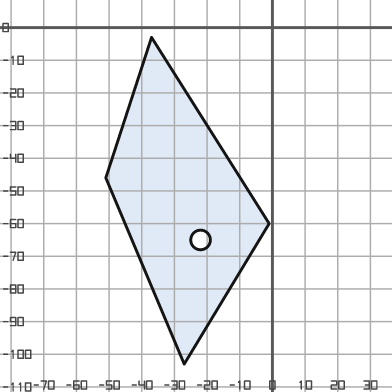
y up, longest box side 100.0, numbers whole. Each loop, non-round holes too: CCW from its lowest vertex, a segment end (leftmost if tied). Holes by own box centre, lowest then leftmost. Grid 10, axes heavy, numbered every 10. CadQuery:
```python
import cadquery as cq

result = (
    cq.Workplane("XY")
    .moveTo(-27.0, -103.0)
    .lineTo(-1.0, -60.0)
    .lineTo(-37.0, -3.0)
    .lineTo(-51.0, -46.0)
    .close()
    .moveTo(-22.0, -65.0)
    .circle(3.0)
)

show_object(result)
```